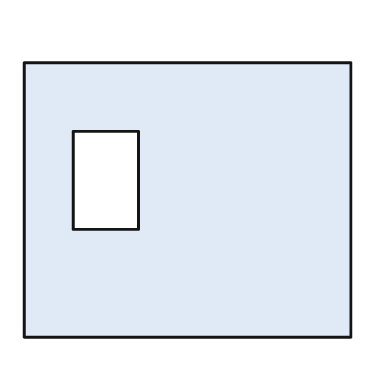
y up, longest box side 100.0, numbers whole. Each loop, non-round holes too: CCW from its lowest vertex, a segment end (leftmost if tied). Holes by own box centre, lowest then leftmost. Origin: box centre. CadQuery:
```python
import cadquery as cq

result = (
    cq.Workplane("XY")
    .moveTo(-50.0, -42.0)
    .lineTo(50.0, -42.0)
    .lineTo(50.0, 42.0)
    .lineTo(-50.0, 42.0)
    .close()
    .moveTo(-35.0, -9.0)
    .lineTo(-15.0, -9.0)
    .lineTo(-15.0, 21.0)
    .lineTo(-35.0, 21.0)
    .close()
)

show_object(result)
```